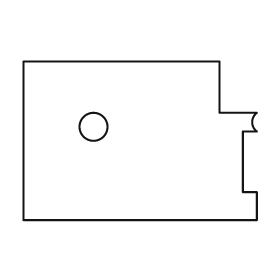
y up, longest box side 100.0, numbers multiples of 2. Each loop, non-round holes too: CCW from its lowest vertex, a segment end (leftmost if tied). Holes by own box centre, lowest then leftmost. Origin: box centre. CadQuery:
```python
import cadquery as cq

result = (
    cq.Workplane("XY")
    .moveTo(-50.0, -34.0)
    .lineTo(50.0, -34.0)
    .lineTo(50.0, -22.0)
    .lineTo(44.0, -22.0)
    .lineTo(44.0, 4.0)
    .lineTo(50.0, 4.0)
    .threePointArc((48.0, 8.0), (50.0, 12.0))
    .lineTo(34.0, 12.0)
    .lineTo(34.0, 34.0)
    .lineTo(-50.0, 34.0)
    .close()
    .moveTo(-20.0, 6.0)
    .circle(6.0)
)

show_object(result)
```